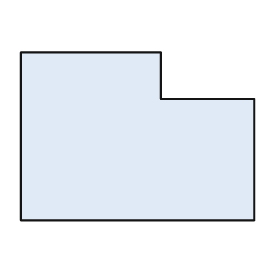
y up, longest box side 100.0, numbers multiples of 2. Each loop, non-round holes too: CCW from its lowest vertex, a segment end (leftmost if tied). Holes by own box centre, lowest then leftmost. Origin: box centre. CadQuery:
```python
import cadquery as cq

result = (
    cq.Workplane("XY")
    .moveTo(-50.0, -36.0)
    .lineTo(50.0, -36.0)
    .lineTo(50.0, 16.0)
    .lineTo(10.0, 16.0)
    .lineTo(10.0, 36.0)
    .lineTo(-50.0, 36.0)
    .close()
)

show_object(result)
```